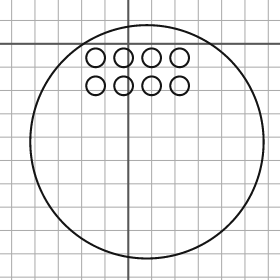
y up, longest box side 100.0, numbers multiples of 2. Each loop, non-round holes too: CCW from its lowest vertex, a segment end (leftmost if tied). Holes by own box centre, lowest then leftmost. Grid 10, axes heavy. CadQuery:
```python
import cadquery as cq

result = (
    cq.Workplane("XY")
    .moveTo(8.0, -42.0)
    .circle(50.0)
    .moveTo(-14.0, -18.0)
    .circle(4.0)
    .moveTo(-2.0, -18.0)
    .circle(4.0)
    .moveTo(10.0, -18.0)
    .circle(4.0)
    .moveTo(22.0, -18.0)
    .circle(4.0)
    .moveTo(-14.0, -6.0)
    .circle(4.0)
    .moveTo(-2.0, -6.0)
    .circle(4.0)
    .moveTo(10.0, -6.0)
    .circle(4.0)
    .moveTo(22.0, -6.0)
    .circle(4.0)
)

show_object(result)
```